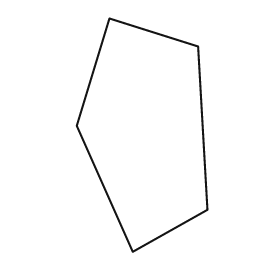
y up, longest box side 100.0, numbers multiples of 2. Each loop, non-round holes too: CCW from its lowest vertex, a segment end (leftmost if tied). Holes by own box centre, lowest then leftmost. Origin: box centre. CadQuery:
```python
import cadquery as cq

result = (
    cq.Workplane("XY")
    .moveTo(-4.0, -50.0)
    .lineTo(28.0, -32.0)
    .lineTo(24.0, 38.0)
    .lineTo(-14.0, 50.0)
    .lineTo(-28.0, 4.0)
    .close()
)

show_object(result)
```